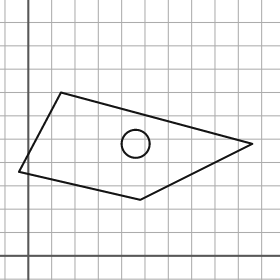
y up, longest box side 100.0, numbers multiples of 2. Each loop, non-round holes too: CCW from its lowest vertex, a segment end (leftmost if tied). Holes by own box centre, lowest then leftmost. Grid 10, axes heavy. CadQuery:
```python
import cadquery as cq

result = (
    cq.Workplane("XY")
    .moveTo(48.0, 24.0)
    .lineTo(96.0, 48.0)
    .lineTo(14.0, 70.0)
    .lineTo(-4.0, 36.0)
    .close()
    .moveTo(46.0, 48.0)
    .circle(6.0)
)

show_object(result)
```